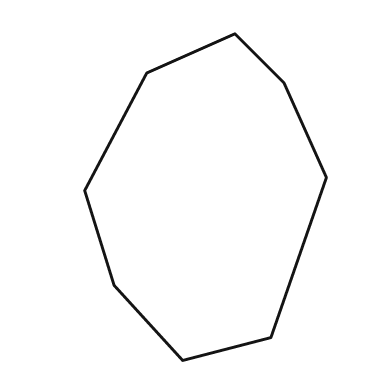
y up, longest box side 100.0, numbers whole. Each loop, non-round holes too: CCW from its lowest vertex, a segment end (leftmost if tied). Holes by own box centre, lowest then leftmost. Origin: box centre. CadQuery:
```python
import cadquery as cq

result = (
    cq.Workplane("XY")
    .moveTo(-7.0, -50.0)
    .lineTo(20.0, -43.0)
    .lineTo(37.0, 6.0)
    .lineTo(24.0, 35.0)
    .lineTo(9.0, 50.0)
    .lineTo(-18.0, 38.0)
    .lineTo(-37.0, 2.0)
    .lineTo(-28.0, -27.0)
    .close()
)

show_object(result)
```